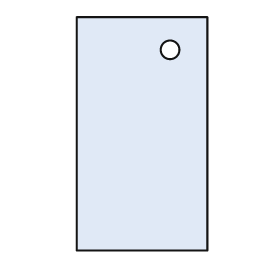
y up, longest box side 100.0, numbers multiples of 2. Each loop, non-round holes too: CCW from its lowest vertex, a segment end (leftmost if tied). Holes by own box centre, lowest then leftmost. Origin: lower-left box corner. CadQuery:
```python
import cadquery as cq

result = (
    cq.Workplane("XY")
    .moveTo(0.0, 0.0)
    .lineTo(56.0, 0.0)
    .lineTo(56.0, 100.0)
    .lineTo(0.0, 100.0)
    .close()
    .moveTo(40.0, 86.0)
    .circle(4.0)
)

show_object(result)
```